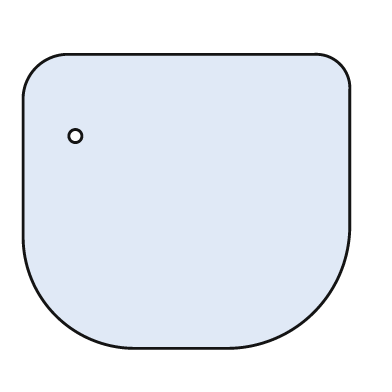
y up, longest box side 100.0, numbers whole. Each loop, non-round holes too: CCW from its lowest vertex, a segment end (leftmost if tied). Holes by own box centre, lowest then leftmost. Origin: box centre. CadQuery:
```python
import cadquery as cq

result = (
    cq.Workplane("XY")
    .moveTo(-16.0, -45.0)
    .lineTo(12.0, -45.0)
    .threePointArc((39.0, -34.0), (50.0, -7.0))
    .lineTo(50.0, 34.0)
    .threePointArc((47.0, 42.0), (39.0, 45.0))
    .lineTo(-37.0, 45.0)
    .threePointArc((-46.0, 41.0), (-50.0, 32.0))
    .lineTo(-50.0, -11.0)
    .threePointArc((-40.0, -35.0), (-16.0, -45.0))
    .close()
    .moveTo(-34.0, 20.0)
    .circle(2.0)
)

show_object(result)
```